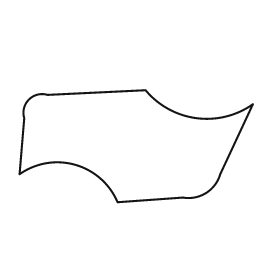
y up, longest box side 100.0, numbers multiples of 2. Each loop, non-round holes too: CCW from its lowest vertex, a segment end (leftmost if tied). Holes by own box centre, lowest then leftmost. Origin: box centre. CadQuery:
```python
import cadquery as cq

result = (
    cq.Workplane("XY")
    .moveTo(-8.0, -24.0)
    .lineTo(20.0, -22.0)
    .threePointArc((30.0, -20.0), (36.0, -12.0))
    .lineTo(50.0, 18.0)
    .threePointArc((26.0, 12.0), (4.0, 24.0))
    .lineTo(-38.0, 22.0)
    .threePointArc((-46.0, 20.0), (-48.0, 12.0))
    .lineTo(-50.0, -12.0)
    .threePointArc((-26.0, -8.0), (-8.0, -24.0))
    .close()
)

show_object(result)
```